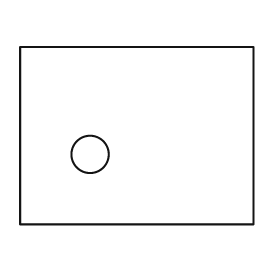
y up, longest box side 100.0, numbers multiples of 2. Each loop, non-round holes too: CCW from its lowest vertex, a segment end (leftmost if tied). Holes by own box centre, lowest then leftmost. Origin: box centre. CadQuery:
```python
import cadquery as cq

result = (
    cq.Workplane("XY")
    .moveTo(-50.0, -38.0)
    .lineTo(50.0, -38.0)
    .lineTo(50.0, 38.0)
    .lineTo(-50.0, 38.0)
    .close()
    .moveTo(-20.0, -8.0)
    .circle(8.0)
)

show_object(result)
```